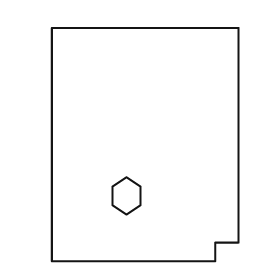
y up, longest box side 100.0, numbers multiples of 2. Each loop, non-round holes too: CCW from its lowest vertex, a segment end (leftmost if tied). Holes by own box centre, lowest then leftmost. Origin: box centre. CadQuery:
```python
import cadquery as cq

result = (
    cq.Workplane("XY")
    .moveTo(-40.0, -50.0)
    .lineTo(30.0, -50.0)
    .lineTo(30.0, -42.0)
    .lineTo(40.0, -42.0)
    .lineTo(40.0, 50.0)
    .lineTo(-40.0, 50.0)
    .close()
    .moveTo(-8.0, -30.0)
    .lineTo(-2.0, -26.0)
    .lineTo(-2.0, -18.0)
    .lineTo(-8.0, -14.0)
    .lineTo(-14.0, -18.0)
    .lineTo(-14.0, -26.0)
    .close()
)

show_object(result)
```